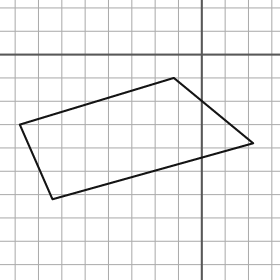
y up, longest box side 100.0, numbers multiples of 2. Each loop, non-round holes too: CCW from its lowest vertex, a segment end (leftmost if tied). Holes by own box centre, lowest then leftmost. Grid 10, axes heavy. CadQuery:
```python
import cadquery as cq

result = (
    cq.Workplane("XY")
    .moveTo(-64.0, -62.0)
    .lineTo(22.0, -38.0)
    .lineTo(-12.0, -10.0)
    .lineTo(-78.0, -30.0)
    .close()
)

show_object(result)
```